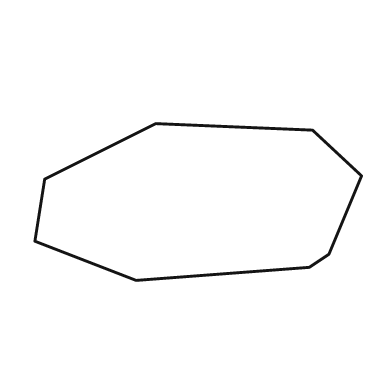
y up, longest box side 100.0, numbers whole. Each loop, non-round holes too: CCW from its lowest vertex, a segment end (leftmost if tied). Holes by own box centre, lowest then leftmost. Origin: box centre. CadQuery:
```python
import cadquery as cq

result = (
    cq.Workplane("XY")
    .moveTo(-19.0, -24.0)
    .lineTo(34.0, -20.0)
    .lineTo(40.0, -16.0)
    .lineTo(50.0, 8.0)
    .lineTo(35.0, 22.0)
    .lineTo(-13.0, 24.0)
    .lineTo(-47.0, 7.0)
    .lineTo(-50.0, -12.0)
    .close()
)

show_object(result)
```